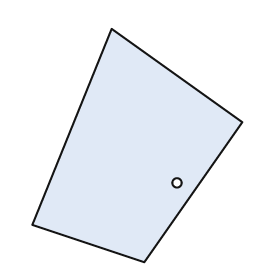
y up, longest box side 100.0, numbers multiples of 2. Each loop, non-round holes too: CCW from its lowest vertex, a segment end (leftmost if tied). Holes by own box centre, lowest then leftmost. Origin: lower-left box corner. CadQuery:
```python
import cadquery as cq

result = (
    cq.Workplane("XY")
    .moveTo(48.0, 0.0)
    .lineTo(90.0, 60.0)
    .lineTo(34.0, 100.0)
    .lineTo(0.0, 16.0)
    .close()
    .moveTo(62.0, 34.0)
    .circle(2.0)
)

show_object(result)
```